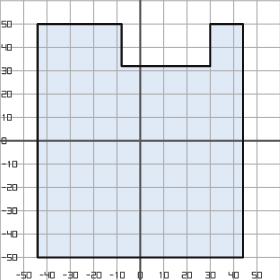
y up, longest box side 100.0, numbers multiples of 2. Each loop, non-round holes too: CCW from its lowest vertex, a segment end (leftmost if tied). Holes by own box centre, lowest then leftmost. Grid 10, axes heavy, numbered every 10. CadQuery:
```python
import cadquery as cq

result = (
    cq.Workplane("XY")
    .moveTo(-44.0, -50.0)
    .lineTo(44.0, -50.0)
    .lineTo(44.0, 50.0)
    .lineTo(30.0, 50.0)
    .lineTo(30.0, 32.0)
    .lineTo(-8.0, 32.0)
    .lineTo(-8.0, 50.0)
    .lineTo(-44.0, 50.0)
    .close()
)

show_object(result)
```